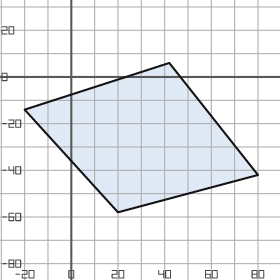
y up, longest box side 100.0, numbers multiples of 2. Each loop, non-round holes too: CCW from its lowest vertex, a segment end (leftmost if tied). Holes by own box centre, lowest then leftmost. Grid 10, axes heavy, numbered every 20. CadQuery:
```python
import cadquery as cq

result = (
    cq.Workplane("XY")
    .moveTo(20.0, -58.0)
    .lineTo(80.0, -42.0)
    .lineTo(42.0, 6.0)
    .lineTo(-20.0, -14.0)
    .close()
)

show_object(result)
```